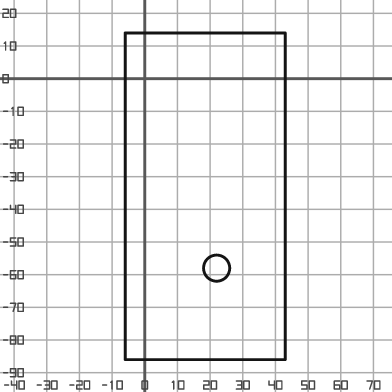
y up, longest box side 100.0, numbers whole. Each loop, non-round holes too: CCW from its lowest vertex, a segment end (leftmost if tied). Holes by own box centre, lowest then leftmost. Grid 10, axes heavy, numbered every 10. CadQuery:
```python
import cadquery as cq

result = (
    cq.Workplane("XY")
    .moveTo(-6.0, -86.0)
    .lineTo(43.0, -86.0)
    .lineTo(43.0, 14.0)
    .lineTo(-6.0, 14.0)
    .close()
    .moveTo(22.0, -58.0)
    .circle(4.0)
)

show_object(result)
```